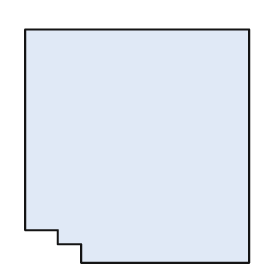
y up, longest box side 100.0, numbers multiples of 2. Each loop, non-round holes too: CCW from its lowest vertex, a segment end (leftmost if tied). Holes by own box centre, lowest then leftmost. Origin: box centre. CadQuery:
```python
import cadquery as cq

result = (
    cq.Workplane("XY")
    .moveTo(-24.0, -50.0)
    .lineTo(48.0, -50.0)
    .lineTo(48.0, 50.0)
    .lineTo(-48.0, 50.0)
    .lineTo(-48.0, -36.0)
    .lineTo(-34.0, -36.0)
    .lineTo(-34.0, -42.0)
    .lineTo(-24.0, -42.0)
    .close()
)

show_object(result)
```